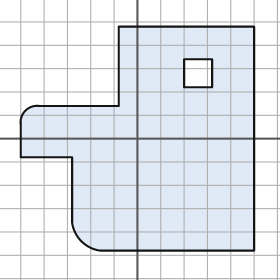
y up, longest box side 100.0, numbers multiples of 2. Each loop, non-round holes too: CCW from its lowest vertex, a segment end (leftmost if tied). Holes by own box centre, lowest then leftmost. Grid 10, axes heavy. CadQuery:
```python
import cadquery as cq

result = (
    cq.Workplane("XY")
    .moveTo(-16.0, -48.0)
    .lineTo(50.0, -48.0)
    .lineTo(50.0, 48.0)
    .lineTo(-8.0, 48.0)
    .lineTo(-8.0, 14.0)
    .lineTo(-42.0, 14.0)
    .threePointArc((-48.0, 12.0), (-50.0, 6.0))
    .lineTo(-50.0, -8.0)
    .lineTo(-28.0, -8.0)
    .lineTo(-28.0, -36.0)
    .threePointArc((-24.0, -44.0), (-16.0, -48.0))
    .close()
    .moveTo(20.0, 22.0)
    .lineTo(32.0, 22.0)
    .lineTo(32.0, 34.0)
    .lineTo(20.0, 34.0)
    .close()
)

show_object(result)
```